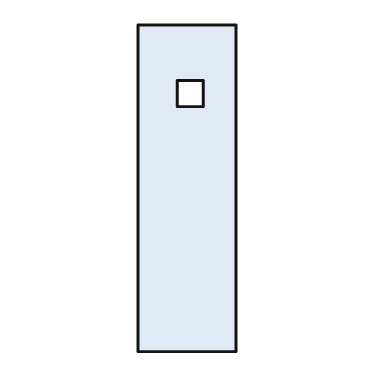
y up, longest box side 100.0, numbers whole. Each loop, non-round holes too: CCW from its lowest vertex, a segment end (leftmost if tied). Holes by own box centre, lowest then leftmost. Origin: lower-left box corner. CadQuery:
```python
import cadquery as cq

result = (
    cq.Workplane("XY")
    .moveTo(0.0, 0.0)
    .lineTo(30.0, 0.0)
    .lineTo(30.0, 100.0)
    .lineTo(0.0, 100.0)
    .close()
    .moveTo(12.0, 75.0)
    .lineTo(20.0, 75.0)
    .lineTo(20.0, 83.0)
    .lineTo(12.0, 83.0)
    .close()
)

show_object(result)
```